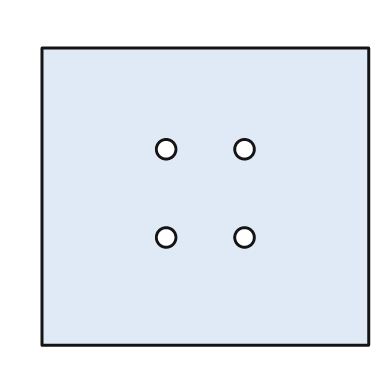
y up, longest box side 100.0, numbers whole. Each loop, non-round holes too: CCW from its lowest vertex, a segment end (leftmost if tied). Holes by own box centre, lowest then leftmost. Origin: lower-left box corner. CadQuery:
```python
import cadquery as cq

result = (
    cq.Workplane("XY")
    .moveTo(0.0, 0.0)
    .lineTo(100.0, 0.0)
    .lineTo(100.0, 91.0)
    .lineTo(0.0, 91.0)
    .close()
    .moveTo(38.0, 33.0)
    .circle(3.0)
    .moveTo(62.0, 33.0)
    .circle(3.0)
    .moveTo(38.0, 60.0)
    .circle(3.0)
    .moveTo(62.0, 60.0)
    .circle(3.0)
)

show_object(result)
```